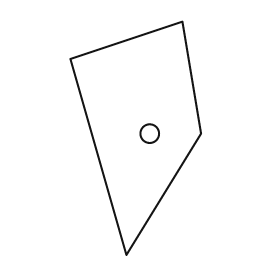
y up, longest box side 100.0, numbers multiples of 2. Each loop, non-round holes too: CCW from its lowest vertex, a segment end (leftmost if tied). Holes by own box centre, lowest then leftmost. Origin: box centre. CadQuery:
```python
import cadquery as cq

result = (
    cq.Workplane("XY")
    .moveTo(-4.0, -50.0)
    .lineTo(28.0, 2.0)
    .lineTo(20.0, 50.0)
    .lineTo(-28.0, 34.0)
    .close()
    .moveTo(6.0, 2.0)
    .circle(4.0)
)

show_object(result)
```